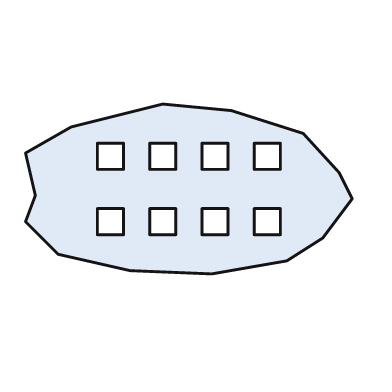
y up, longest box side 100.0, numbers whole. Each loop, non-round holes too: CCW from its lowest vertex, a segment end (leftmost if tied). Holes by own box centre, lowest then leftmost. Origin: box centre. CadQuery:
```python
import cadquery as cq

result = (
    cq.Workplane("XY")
    .moveTo(7.0, -26.0)
    .lineTo(30.0, -22.0)
    .lineTo(41.0, -15.0)
    .lineTo(50.0, -3.0)
    .lineTo(46.0, 5.0)
    .lineTo(35.0, 17.0)
    .lineTo(13.0, 24.0)
    .lineTo(-8.0, 26.0)
    .lineTo(-36.0, 19.0)
    .lineTo(-50.0, 11.0)
    .lineTo(-47.0, -2.0)
    .lineTo(-50.0, -10.0)
    .lineTo(-40.0, -20.0)
    .lineTo(-18.0, -25.0)
    .close()
    .moveTo(-28.0, -14.0)
    .lineTo(-20.0, -14.0)
    .lineTo(-20.0, -6.0)
    .lineTo(-28.0, -6.0)
    .close()
    .moveTo(-12.0, -14.0)
    .lineTo(-4.0, -14.0)
    .lineTo(-4.0, -6.0)
    .lineTo(-12.0, -6.0)
    .close()
    .moveTo(4.0, -14.0)
    .lineTo(12.0, -14.0)
    .lineTo(12.0, -6.0)
    .lineTo(4.0, -6.0)
    .close()
    .moveTo(20.0, -14.0)
    .lineTo(28.0, -14.0)
    .lineTo(28.0, -6.0)
    .lineTo(20.0, -6.0)
    .close()
    .moveTo(-28.0, 6.0)
    .lineTo(-20.0, 6.0)
    .lineTo(-20.0, 14.0)
    .lineTo(-28.0, 14.0)
    .close()
    .moveTo(-12.0, 6.0)
    .lineTo(-4.0, 6.0)
    .lineTo(-4.0, 14.0)
    .lineTo(-12.0, 14.0)
    .close()
    .moveTo(4.0, 6.0)
    .lineTo(12.0, 6.0)
    .lineTo(12.0, 14.0)
    .lineTo(4.0, 14.0)
    .close()
    .moveTo(20.0, 6.0)
    .lineTo(28.0, 6.0)
    .lineTo(28.0, 14.0)
    .lineTo(20.0, 14.0)
    .close()
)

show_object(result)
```